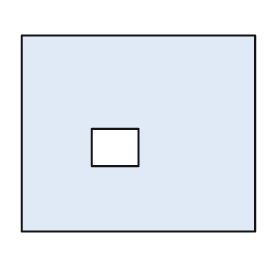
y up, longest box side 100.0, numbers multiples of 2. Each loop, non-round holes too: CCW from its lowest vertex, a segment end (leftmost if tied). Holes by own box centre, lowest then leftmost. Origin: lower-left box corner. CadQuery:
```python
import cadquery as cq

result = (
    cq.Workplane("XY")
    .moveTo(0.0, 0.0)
    .lineTo(100.0, 0.0)
    .lineTo(100.0, 84.0)
    .lineTo(0.0, 84.0)
    .close()
    .moveTo(30.0, 28.0)
    .lineTo(50.0, 28.0)
    .lineTo(50.0, 44.0)
    .lineTo(30.0, 44.0)
    .close()
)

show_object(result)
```